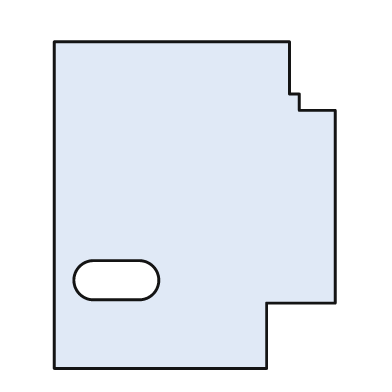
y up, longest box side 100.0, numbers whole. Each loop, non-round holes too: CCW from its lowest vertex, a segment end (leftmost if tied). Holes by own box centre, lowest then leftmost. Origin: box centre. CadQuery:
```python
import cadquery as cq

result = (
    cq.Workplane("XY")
    .moveTo(-43.0, -50.0)
    .lineTo(22.0, -50.0)
    .lineTo(22.0, -30.0)
    .lineTo(43.0, -30.0)
    .lineTo(43.0, 29.0)
    .lineTo(32.0, 29.0)
    .lineTo(32.0, 34.0)
    .lineTo(29.0, 34.0)
    .lineTo(29.0, 50.0)
    .lineTo(-43.0, 50.0)
    .close()
    .moveTo(-31.0, -29.0)
    .lineTo(-17.0, -29.0)
    .threePointArc((-11.0, -23.0), (-17.0, -17.0))
    .lineTo(-31.0, -17.0)
    .threePointArc((-37.0, -23.0), (-31.0, -29.0))
    .close()
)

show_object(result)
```